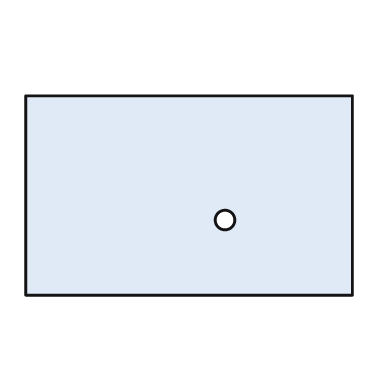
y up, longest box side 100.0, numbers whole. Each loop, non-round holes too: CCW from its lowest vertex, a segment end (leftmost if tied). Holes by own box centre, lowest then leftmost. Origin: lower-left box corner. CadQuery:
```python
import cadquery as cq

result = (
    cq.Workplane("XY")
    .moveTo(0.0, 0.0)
    .lineTo(100.0, 0.0)
    .lineTo(100.0, 61.0)
    .lineTo(0.0, 61.0)
    .close()
    .moveTo(61.0, 23.0)
    .circle(3.0)
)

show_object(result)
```